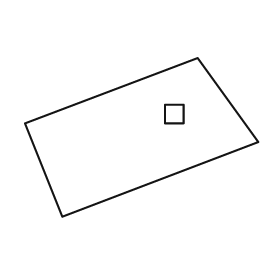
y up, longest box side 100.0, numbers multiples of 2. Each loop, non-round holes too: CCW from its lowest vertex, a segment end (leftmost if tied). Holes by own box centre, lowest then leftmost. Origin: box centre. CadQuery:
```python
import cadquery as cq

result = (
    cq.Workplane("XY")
    .moveTo(-34.0, -34.0)
    .lineTo(50.0, -2.0)
    .lineTo(24.0, 34.0)
    .lineTo(-50.0, 6.0)
    .close()
    .moveTo(10.0, 6.0)
    .lineTo(18.0, 6.0)
    .lineTo(18.0, 14.0)
    .lineTo(10.0, 14.0)
    .close()
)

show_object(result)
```